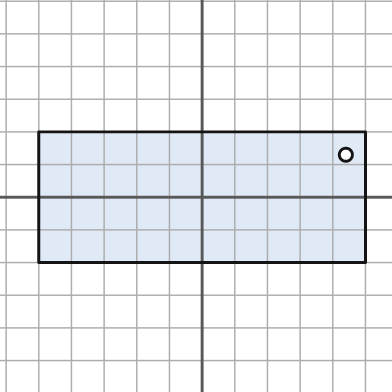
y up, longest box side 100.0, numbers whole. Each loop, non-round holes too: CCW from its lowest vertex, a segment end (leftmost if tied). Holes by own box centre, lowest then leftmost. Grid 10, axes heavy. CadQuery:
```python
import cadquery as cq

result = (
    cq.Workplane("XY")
    .moveTo(-50.0, -20.0)
    .lineTo(50.0, -20.0)
    .lineTo(50.0, 20.0)
    .lineTo(-50.0, 20.0)
    .close()
    .moveTo(44.0, 13.0)
    .circle(2.0)
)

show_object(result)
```